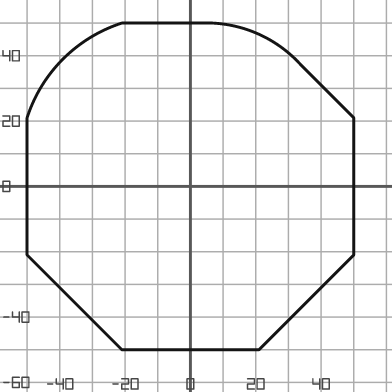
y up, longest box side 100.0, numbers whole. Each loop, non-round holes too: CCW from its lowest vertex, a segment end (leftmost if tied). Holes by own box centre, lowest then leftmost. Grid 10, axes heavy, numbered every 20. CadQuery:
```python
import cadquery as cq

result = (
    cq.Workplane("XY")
    .moveTo(-21.0, -50.0)
    .lineTo(21.0, -50.0)
    .lineTo(50.0, -21.0)
    .lineTo(50.0, 21.0)
    .lineTo(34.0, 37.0)
    .threePointArc((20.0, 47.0), (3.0, 50.0))
    .lineTo(-21.0, 50.0)
    .threePointArc((-39.0, 39.0), (-50.0, 21.0))
    .lineTo(-50.0, -21.0)
    .close()
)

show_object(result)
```